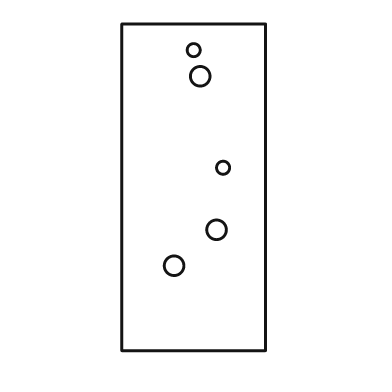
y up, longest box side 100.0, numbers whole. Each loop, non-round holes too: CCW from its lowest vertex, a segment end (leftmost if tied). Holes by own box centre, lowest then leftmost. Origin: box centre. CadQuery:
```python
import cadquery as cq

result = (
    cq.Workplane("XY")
    .moveTo(-22.0, -50.0)
    .lineTo(22.0, -50.0)
    .lineTo(22.0, 50.0)
    .lineTo(-22.0, 50.0)
    .close()
    .moveTo(-6.0, -24.0)
    .circle(3.0)
    .moveTo(7.0, -13.0)
    .circle(3.0)
    .moveTo(9.0, 6.0)
    .circle(2.0)
    .moveTo(2.0, 34.0)
    .circle(3.0)
    .moveTo(0.0, 42.0)
    .circle(2.0)
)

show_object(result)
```